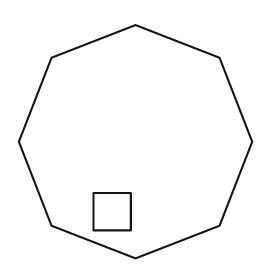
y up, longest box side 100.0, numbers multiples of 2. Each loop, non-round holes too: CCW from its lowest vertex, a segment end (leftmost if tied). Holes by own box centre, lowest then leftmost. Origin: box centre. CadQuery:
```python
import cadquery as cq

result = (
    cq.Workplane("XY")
    .moveTo(0.0, -50.0)
    .lineTo(36.0, -36.0)
    .lineTo(50.0, 0.0)
    .lineTo(36.0, 36.0)
    .lineTo(0.0, 50.0)
    .lineTo(-36.0, 36.0)
    .lineTo(-50.0, 0.0)
    .lineTo(-36.0, -36.0)
    .close()
    .moveTo(-18.0, -38.0)
    .lineTo(-2.0, -38.0)
    .lineTo(-2.0, -22.0)
    .lineTo(-18.0, -22.0)
    .close()
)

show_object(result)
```